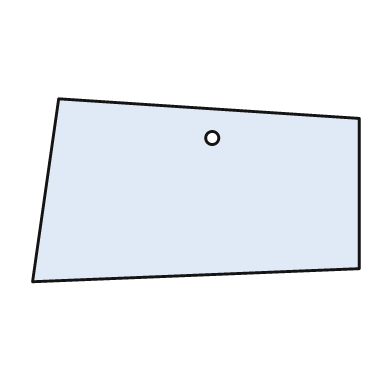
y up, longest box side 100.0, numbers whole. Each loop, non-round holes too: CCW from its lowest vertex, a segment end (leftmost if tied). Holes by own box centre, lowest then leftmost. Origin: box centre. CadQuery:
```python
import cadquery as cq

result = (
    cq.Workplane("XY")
    .moveTo(-50.0, -28.0)
    .lineTo(50.0, -24.0)
    .lineTo(50.0, 22.0)
    .lineTo(-42.0, 28.0)
    .close()
    .moveTo(5.0, 16.0)
    .circle(2.0)
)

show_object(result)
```